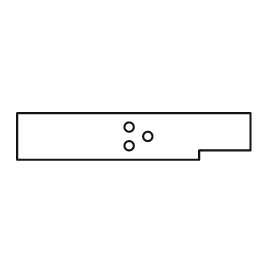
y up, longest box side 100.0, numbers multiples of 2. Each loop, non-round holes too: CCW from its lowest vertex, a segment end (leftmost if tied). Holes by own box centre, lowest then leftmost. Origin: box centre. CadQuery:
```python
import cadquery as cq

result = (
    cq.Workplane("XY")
    .moveTo(-50.0, -10.0)
    .lineTo(28.0, -10.0)
    .lineTo(28.0, -6.0)
    .lineTo(50.0, -6.0)
    .lineTo(50.0, 10.0)
    .lineTo(-50.0, 10.0)
    .close()
    .moveTo(-2.0, -4.0)
    .circle(2.0)
    .moveTo(6.0, 0.0)
    .circle(2.0)
    .moveTo(-2.0, 4.0)
    .circle(2.0)
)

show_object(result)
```